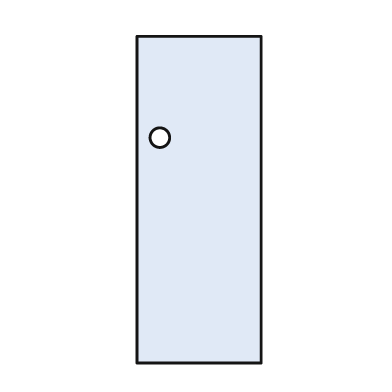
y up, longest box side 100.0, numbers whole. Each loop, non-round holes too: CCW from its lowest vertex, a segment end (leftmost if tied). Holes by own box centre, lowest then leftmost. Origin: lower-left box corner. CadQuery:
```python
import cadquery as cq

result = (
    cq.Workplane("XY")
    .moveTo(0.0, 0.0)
    .lineTo(38.0, 0.0)
    .lineTo(38.0, 100.0)
    .lineTo(0.0, 100.0)
    .close()
    .moveTo(7.0, 69.0)
    .circle(3.0)
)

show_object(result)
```